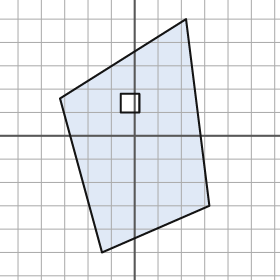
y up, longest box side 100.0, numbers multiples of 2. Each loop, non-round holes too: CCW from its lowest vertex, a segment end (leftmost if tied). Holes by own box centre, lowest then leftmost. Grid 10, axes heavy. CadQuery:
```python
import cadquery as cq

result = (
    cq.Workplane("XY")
    .moveTo(-14.0, -50.0)
    .lineTo(32.0, -30.0)
    .lineTo(22.0, 50.0)
    .lineTo(-32.0, 16.0)
    .close()
    .moveTo(-6.0, 10.0)
    .lineTo(2.0, 10.0)
    .lineTo(2.0, 18.0)
    .lineTo(-6.0, 18.0)
    .close()
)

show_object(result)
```